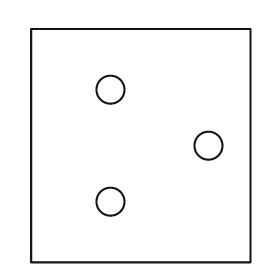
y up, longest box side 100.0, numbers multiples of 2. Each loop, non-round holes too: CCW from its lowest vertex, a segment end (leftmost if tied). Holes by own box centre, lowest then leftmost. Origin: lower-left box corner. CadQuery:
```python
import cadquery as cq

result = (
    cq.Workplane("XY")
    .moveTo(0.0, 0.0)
    .lineTo(94.0, 0.0)
    .lineTo(94.0, 100.0)
    .lineTo(0.0, 100.0)
    .close()
    .moveTo(34.0, 26.0)
    .circle(6.0)
    .moveTo(76.0, 50.0)
    .circle(6.0)
    .moveTo(34.0, 74.0)
    .circle(6.0)
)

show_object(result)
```